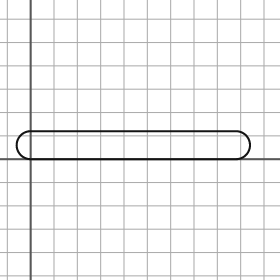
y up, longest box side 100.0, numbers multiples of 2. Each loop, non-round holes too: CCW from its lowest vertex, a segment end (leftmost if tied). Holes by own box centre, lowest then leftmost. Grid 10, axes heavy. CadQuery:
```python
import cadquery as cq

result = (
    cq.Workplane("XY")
    .moveTo(0.0, 0.0)
    .lineTo(88.0, 0.0)
    .threePointArc((94.0, 6.0), (88.0, 12.0))
    .lineTo(0.0, 12.0)
    .threePointArc((-6.0, 6.0), (0.0, 0.0))
    .close()
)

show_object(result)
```